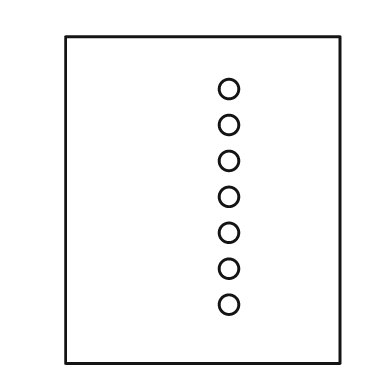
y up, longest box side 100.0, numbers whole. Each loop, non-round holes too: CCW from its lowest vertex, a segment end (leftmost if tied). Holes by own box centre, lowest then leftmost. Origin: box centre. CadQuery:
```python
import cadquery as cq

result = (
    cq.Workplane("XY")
    .moveTo(-42.0, -50.0)
    .lineTo(42.0, -50.0)
    .lineTo(42.0, 50.0)
    .lineTo(-42.0, 50.0)
    .close()
    .moveTo(8.0, -32.0)
    .circle(3.0)
    .moveTo(8.0, -21.0)
    .circle(3.0)
    .moveTo(8.0, -10.0)
    .circle(3.0)
    .moveTo(8.0, 1.0)
    .circle(3.0)
    .moveTo(8.0, 12.0)
    .circle(3.0)
    .moveTo(8.0, 23.0)
    .circle(3.0)
    .moveTo(8.0, 34.0)
    .circle(3.0)
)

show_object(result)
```